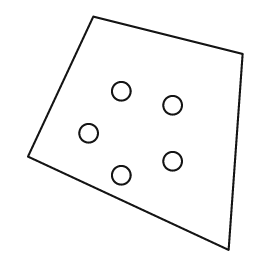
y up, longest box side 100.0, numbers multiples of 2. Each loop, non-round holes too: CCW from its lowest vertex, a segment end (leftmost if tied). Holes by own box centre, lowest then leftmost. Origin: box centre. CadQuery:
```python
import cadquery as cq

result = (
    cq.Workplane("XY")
    .moveTo(40.0, -50.0)
    .lineTo(46.0, 34.0)
    .lineTo(-18.0, 50.0)
    .lineTo(-46.0, -10.0)
    .close()
    .moveTo(-6.0, -18.0)
    .circle(4.0)
    .moveTo(16.0, -12.0)
    .circle(4.0)
    .moveTo(-20.0, 0.0)
    .circle(4.0)
    .moveTo(16.0, 12.0)
    .circle(4.0)
    .moveTo(-6.0, 18.0)
    .circle(4.0)
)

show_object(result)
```